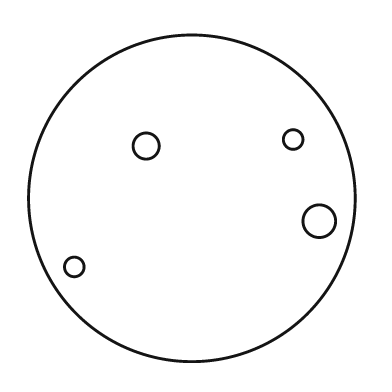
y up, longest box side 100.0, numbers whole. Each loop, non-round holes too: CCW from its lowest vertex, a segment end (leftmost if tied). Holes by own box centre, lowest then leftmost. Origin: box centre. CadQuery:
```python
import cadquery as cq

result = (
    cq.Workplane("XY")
    .moveTo(0.0, 0.0)
    .circle(50.0)
    .moveTo(-36.0, -21.0)
    .circle(3.0)
    .moveTo(39.0, -7.0)
    .circle(5.0)
    .moveTo(-14.0, 16.0)
    .circle(4.0)
    .moveTo(31.0, 18.0)
    .circle(3.0)
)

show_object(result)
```